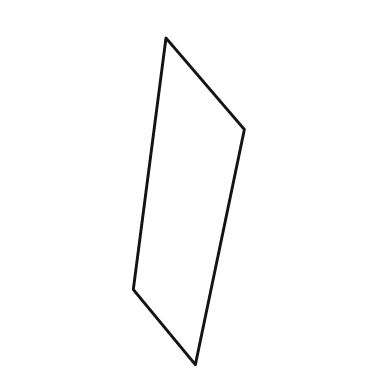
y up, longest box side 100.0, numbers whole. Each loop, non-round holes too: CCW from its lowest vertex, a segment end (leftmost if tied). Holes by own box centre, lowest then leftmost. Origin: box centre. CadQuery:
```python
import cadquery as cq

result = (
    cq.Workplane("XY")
    .moveTo(2.0, -50.0)
    .lineTo(17.0, 22.0)
    .lineTo(-7.0, 50.0)
    .lineTo(-17.0, -27.0)
    .close()
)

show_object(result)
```